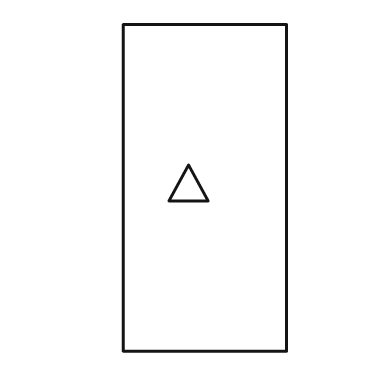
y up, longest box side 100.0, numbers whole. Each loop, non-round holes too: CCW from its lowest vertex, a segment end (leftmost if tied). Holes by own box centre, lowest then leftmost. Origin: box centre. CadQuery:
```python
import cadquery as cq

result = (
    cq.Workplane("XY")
    .moveTo(-25.0, -50.0)
    .lineTo(25.0, -50.0)
    .lineTo(25.0, 50.0)
    .lineTo(-25.0, 50.0)
    .close()
    .moveTo(-11.0, -4.0)
    .lineTo(1.0, -4.0)
    .lineTo(-5.0, 7.0)
    .close()
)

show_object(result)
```